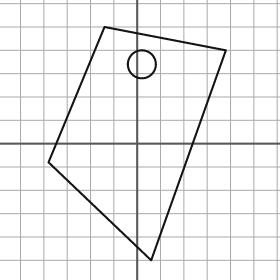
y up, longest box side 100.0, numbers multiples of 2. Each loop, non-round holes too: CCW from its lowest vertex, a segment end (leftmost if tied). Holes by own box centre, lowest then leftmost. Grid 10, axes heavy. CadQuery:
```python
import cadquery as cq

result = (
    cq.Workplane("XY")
    .moveTo(6.0, -50.0)
    .lineTo(38.0, 40.0)
    .lineTo(-14.0, 50.0)
    .lineTo(-38.0, -8.0)
    .close()
    .moveTo(2.0, 34.0)
    .circle(6.0)
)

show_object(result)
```